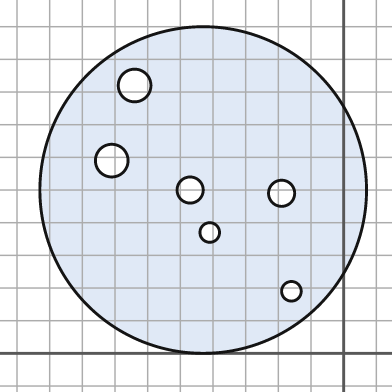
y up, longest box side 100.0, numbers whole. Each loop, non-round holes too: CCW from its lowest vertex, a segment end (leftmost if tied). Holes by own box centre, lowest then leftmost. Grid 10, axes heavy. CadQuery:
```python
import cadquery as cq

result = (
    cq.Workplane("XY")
    .moveTo(-43.0, 50.0)
    .circle(50.0)
    .moveTo(-16.0, 19.0)
    .circle(3.0)
    .moveTo(-41.0, 37.0)
    .circle(3.0)
    .moveTo(-19.0, 49.0)
    .circle(4.0)
    .moveTo(-47.0, 50.0)
    .circle(4.0)
    .moveTo(-71.0, 59.0)
    .circle(5.0)
    .moveTo(-64.0, 82.0)
    .circle(5.0)
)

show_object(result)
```